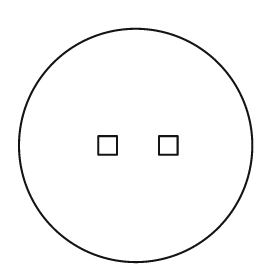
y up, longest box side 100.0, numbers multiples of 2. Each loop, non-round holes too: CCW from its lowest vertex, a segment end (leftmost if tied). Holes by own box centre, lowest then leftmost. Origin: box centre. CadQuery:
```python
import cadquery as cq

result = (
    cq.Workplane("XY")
    .moveTo(0.0, 0.0)
    .circle(50.0)
    .moveTo(-16.0, -4.0)
    .lineTo(-8.0, -4.0)
    .lineTo(-8.0, 4.0)
    .lineTo(-16.0, 4.0)
    .close()
    .moveTo(10.0, -4.0)
    .lineTo(18.0, -4.0)
    .lineTo(18.0, 4.0)
    .lineTo(10.0, 4.0)
    .close()
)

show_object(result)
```